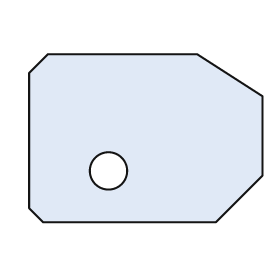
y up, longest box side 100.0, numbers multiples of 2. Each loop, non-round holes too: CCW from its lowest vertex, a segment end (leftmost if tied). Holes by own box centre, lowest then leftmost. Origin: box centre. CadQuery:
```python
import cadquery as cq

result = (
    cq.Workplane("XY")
    .moveTo(-44.0, -36.0)
    .lineTo(30.0, -36.0)
    .lineTo(50.0, -16.0)
    .lineTo(50.0, 18.0)
    .lineTo(22.0, 36.0)
    .lineTo(-42.0, 36.0)
    .lineTo(-50.0, 28.0)
    .lineTo(-50.0, -30.0)
    .close()
    .moveTo(-16.0, -14.0)
    .circle(8.0)
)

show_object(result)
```